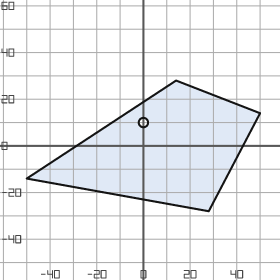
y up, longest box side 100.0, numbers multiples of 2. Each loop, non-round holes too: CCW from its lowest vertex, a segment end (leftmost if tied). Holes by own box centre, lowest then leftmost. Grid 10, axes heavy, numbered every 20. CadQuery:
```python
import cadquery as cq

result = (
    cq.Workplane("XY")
    .moveTo(28.0, -28.0)
    .lineTo(50.0, 14.0)
    .lineTo(14.0, 28.0)
    .lineTo(-50.0, -14.0)
    .close()
    .moveTo(0.0, 10.0)
    .circle(2.0)
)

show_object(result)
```